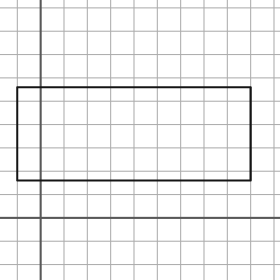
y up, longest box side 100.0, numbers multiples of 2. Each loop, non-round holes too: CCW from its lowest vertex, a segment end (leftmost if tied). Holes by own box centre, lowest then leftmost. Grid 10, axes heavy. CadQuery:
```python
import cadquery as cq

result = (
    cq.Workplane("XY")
    .moveTo(-10.0, 16.0)
    .lineTo(90.0, 16.0)
    .lineTo(90.0, 56.0)
    .lineTo(-10.0, 56.0)
    .close()
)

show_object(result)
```